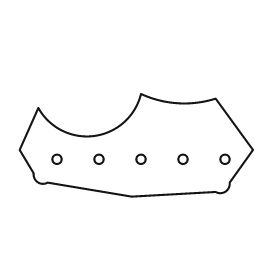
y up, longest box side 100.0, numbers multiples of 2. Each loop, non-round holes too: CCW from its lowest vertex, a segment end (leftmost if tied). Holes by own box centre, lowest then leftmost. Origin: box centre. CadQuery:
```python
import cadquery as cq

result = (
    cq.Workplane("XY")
    .moveTo(-2.0, -22.0)
    .lineTo(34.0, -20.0)
    .threePointArc((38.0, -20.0), (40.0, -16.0))
    .lineTo(50.0, -2.0)
    .lineTo(34.0, 20.0)
    .threePointArc((18.0, 18.0), (2.0, 22.0))
    .threePointArc((-18.0, 4.0), (-42.0, 16.0))
    .lineTo(-50.0, -2.0)
    .lineTo(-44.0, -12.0)
    .threePointArc((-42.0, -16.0), (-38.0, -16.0))
    .close()
    .moveTo(-34.0, -6.0)
    .circle(2.0)
    .moveTo(-16.0, -6.0)
    .circle(2.0)
    .moveTo(2.0, -6.0)
    .circle(2.0)
    .moveTo(20.0, -6.0)
    .circle(2.0)
    .moveTo(38.0, -6.0)
    .circle(2.0)
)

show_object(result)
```